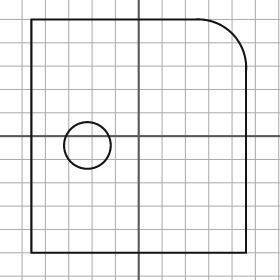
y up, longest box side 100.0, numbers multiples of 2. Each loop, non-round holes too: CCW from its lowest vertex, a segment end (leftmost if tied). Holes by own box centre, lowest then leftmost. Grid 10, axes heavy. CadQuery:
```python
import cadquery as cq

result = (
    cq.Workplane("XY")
    .moveTo(-46.0, -50.0)
    .lineTo(46.0, -50.0)
    .lineTo(46.0, 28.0)
    .threePointArc((40.0, 44.0), (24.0, 50.0))
    .lineTo(-46.0, 50.0)
    .close()
    .moveTo(-22.0, -4.0)
    .circle(10.0)
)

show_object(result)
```